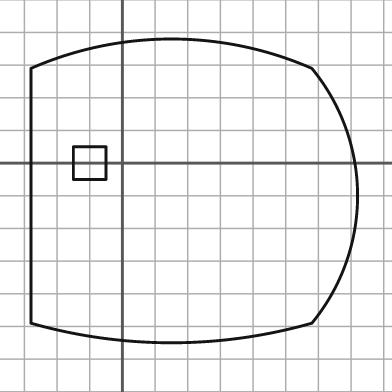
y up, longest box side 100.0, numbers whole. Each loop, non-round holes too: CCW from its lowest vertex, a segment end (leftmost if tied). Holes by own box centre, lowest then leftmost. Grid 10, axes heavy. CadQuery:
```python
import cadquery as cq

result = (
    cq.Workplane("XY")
    .moveTo(-28.0, -49.0)
    .threePointArc((15.0, -55.0), (58.0, -49.0))
    .threePointArc((72.0, -10.0), (58.0, 29.0))
    .threePointArc((15.0, 38.0), (-28.0, 29.0))
    .close()
    .moveTo(-15.0, -5.0)
    .lineTo(-5.0, -5.0)
    .lineTo(-5.0, 5.0)
    .lineTo(-15.0, 5.0)
    .close()
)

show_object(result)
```